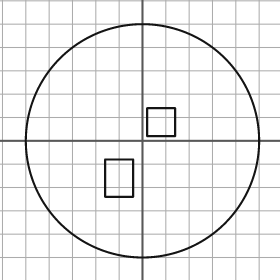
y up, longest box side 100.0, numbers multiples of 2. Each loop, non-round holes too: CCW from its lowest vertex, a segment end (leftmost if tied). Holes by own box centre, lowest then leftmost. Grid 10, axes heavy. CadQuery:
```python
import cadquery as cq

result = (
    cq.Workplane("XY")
    .moveTo(0.0, 0.0)
    .circle(50.0)
    .moveTo(-16.0, -24.0)
    .lineTo(-4.0, -24.0)
    .lineTo(-4.0, -8.0)
    .lineTo(-16.0, -8.0)
    .close()
    .moveTo(2.0, 2.0)
    .lineTo(14.0, 2.0)
    .lineTo(14.0, 14.0)
    .lineTo(2.0, 14.0)
    .close()
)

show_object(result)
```